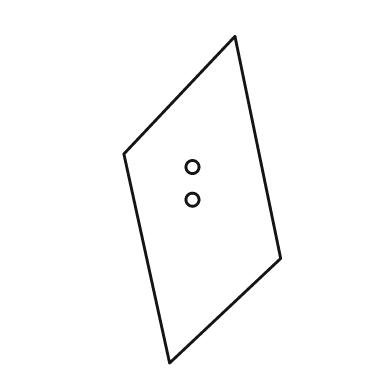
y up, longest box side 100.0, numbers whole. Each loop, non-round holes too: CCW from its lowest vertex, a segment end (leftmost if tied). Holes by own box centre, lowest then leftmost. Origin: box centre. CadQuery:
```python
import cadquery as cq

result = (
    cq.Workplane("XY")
    .moveTo(-10.0, -50.0)
    .lineTo(24.0, -18.0)
    .lineTo(10.0, 50.0)
    .lineTo(-24.0, 14.0)
    .close()
    .moveTo(-3.0, 0.0)
    .circle(2.0)
    .moveTo(-3.0, 10.0)
    .circle(2.0)
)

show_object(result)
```